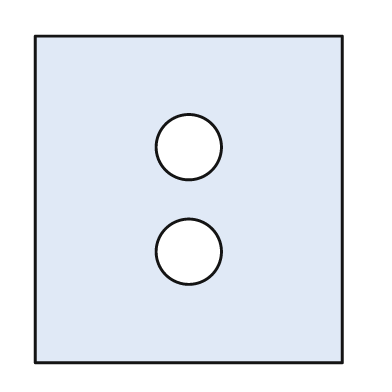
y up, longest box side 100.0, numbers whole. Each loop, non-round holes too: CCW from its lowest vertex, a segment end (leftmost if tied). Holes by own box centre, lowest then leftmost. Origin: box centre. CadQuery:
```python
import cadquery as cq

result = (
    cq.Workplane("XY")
    .moveTo(-47.0, -50.0)
    .lineTo(47.0, -50.0)
    .lineTo(47.0, 50.0)
    .lineTo(-47.0, 50.0)
    .close()
    .moveTo(0.0, -16.0)
    .circle(10.0)
    .moveTo(0.0, 16.0)
    .circle(10.0)
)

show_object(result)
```